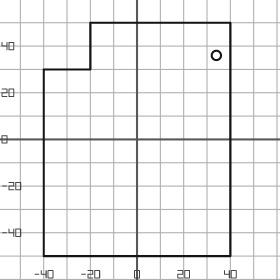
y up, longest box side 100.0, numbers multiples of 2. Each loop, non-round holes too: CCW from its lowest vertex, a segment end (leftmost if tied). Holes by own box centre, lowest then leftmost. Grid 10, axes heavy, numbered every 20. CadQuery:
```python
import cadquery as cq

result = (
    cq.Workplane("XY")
    .moveTo(-40.0, -50.0)
    .lineTo(40.0, -50.0)
    .lineTo(40.0, 50.0)
    .lineTo(-20.0, 50.0)
    .lineTo(-20.0, 30.0)
    .lineTo(-40.0, 30.0)
    .close()
    .moveTo(34.0, 36.0)
    .circle(2.0)
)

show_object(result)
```